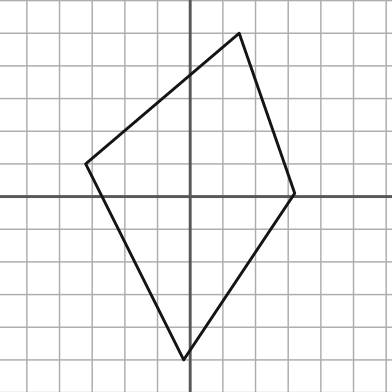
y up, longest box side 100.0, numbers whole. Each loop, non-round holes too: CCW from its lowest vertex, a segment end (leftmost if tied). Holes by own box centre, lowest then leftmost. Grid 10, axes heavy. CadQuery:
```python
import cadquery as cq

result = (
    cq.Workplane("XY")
    .moveTo(-2.0, -50.0)
    .lineTo(32.0, 1.0)
    .lineTo(15.0, 50.0)
    .lineTo(-32.0, 10.0)
    .close()
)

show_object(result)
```